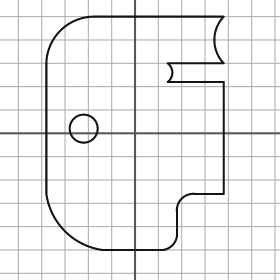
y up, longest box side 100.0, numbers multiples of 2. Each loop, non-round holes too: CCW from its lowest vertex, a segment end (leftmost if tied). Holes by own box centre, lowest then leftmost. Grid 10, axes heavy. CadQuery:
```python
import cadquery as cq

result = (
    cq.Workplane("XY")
    .moveTo(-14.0, -50.0)
    .lineTo(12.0, -50.0)
    .threePointArc((16.0, -48.0), (18.0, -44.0))
    .lineTo(18.0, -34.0)
    .threePointArc((20.0, -28.0), (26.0, -26.0))
    .lineTo(38.0, -26.0)
    .lineTo(38.0, 22.0)
    .lineTo(14.0, 22.0)
    .threePointArc((16.0, 26.0), (14.0, 30.0))
    .lineTo(38.0, 30.0)
    .threePointArc((34.0, 40.0), (38.0, 50.0))
    .lineTo(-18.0, 50.0)
    .threePointArc((-32.0, 44.0), (-38.0, 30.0))
    .lineTo(-38.0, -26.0)
    .threePointArc((-30.0, -42.0), (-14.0, -50.0))
    .close()
    .moveTo(-22.0, 2.0)
    .circle(6.0)
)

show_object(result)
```